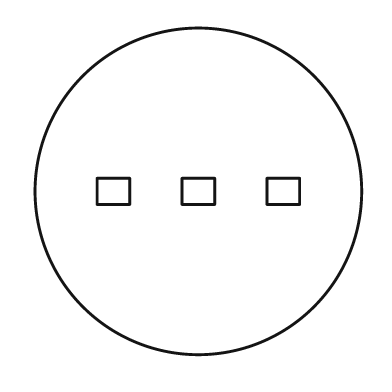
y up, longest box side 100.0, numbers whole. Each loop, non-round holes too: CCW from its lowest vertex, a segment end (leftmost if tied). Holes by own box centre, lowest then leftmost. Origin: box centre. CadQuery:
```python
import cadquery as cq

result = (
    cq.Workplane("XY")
    .moveTo(0.0, 0.0)
    .circle(50.0)
    .moveTo(-31.0, -4.0)
    .lineTo(-21.0, -4.0)
    .lineTo(-21.0, 4.0)
    .lineTo(-31.0, 4.0)
    .close()
    .moveTo(-5.0, -4.0)
    .lineTo(5.0, -4.0)
    .lineTo(5.0, 4.0)
    .lineTo(-5.0, 4.0)
    .close()
    .moveTo(21.0, -4.0)
    .lineTo(31.0, -4.0)
    .lineTo(31.0, 4.0)
    .lineTo(21.0, 4.0)
    .close()
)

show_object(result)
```